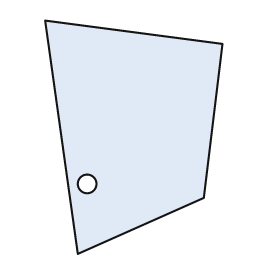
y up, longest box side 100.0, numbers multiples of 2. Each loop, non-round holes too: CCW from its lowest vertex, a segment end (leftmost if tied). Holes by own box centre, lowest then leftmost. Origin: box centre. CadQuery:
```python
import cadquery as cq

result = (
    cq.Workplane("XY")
    .moveTo(-24.0, -50.0)
    .lineTo(30.0, -26.0)
    .lineTo(38.0, 40.0)
    .lineTo(-38.0, 50.0)
    .close()
    .moveTo(-20.0, -20.0)
    .circle(4.0)
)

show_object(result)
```